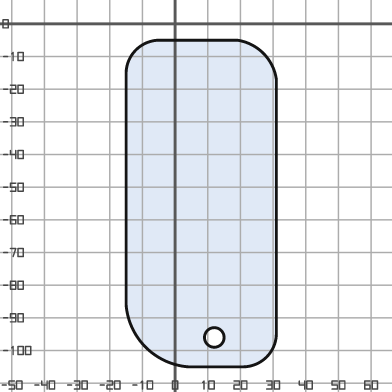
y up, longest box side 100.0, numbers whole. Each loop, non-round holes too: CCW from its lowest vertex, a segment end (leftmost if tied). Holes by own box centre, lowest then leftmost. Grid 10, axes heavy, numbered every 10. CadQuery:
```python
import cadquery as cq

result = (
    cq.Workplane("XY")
    .moveTo(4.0, -105.0)
    .lineTo(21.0, -105.0)
    .threePointArc((28.0, -102.0), (31.0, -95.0))
    .lineTo(31.0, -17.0)
    .threePointArc((27.0, -9.0), (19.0, -5.0))
    .lineTo(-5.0, -5.0)
    .threePointArc((-12.0, -8.0), (-15.0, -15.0))
    .lineTo(-15.0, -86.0)
    .threePointArc((-9.0, -99.0), (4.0, -105.0))
    .close()
    .moveTo(12.0, -96.0)
    .circle(3.0)
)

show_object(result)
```